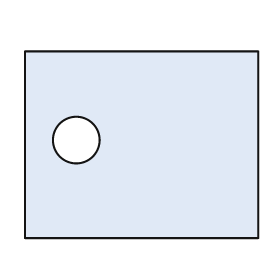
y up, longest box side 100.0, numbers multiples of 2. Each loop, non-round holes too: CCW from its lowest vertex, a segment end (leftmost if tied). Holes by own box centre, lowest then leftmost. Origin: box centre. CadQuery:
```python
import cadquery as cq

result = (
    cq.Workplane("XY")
    .moveTo(-50.0, -40.0)
    .lineTo(50.0, -40.0)
    .lineTo(50.0, 40.0)
    .lineTo(-50.0, 40.0)
    .close()
    .moveTo(-28.0, 2.0)
    .circle(10.0)
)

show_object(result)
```